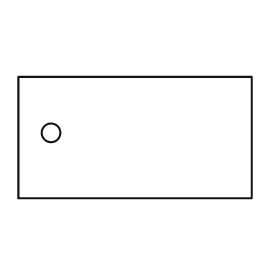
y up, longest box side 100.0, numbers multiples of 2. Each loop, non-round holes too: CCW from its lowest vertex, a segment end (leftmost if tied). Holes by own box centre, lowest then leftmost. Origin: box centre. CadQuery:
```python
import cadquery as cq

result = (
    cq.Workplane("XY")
    .moveTo(-50.0, -26.0)
    .lineTo(50.0, -26.0)
    .lineTo(50.0, 26.0)
    .lineTo(-50.0, 26.0)
    .close()
    .moveTo(-36.0, 2.0)
    .circle(4.0)
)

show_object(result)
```